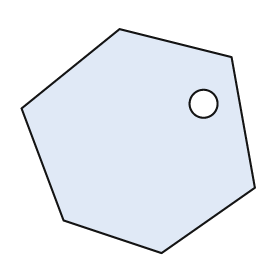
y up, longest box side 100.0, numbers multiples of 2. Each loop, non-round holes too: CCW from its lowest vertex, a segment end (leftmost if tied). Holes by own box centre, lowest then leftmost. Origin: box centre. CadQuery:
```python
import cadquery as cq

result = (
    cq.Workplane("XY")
    .moveTo(10.0, -48.0)
    .lineTo(50.0, -20.0)
    .lineTo(40.0, 36.0)
    .lineTo(-8.0, 48.0)
    .lineTo(-50.0, 14.0)
    .lineTo(-32.0, -34.0)
    .close()
    .moveTo(28.0, 16.0)
    .circle(6.0)
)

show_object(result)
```